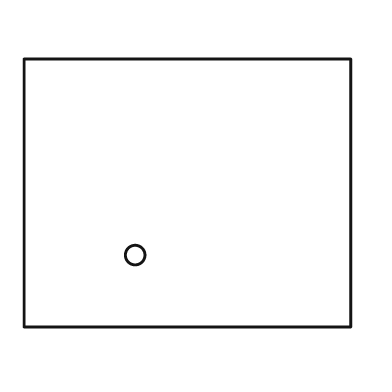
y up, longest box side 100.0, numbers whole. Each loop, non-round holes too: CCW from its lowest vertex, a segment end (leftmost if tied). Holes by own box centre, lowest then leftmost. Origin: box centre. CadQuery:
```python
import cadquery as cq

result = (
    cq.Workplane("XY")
    .moveTo(-50.0, -41.0)
    .lineTo(50.0, -41.0)
    .lineTo(50.0, 41.0)
    .lineTo(-50.0, 41.0)
    .close()
    .moveTo(-16.0, -19.0)
    .circle(3.0)
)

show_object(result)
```